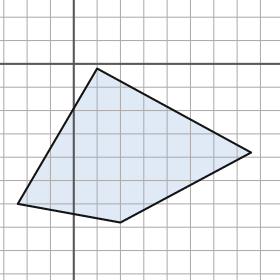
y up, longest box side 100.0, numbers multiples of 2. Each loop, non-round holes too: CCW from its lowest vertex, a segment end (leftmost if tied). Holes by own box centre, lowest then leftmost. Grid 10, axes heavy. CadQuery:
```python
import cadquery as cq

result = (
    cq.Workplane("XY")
    .moveTo(20.0, -68.0)
    .lineTo(76.0, -38.0)
    .lineTo(10.0, -2.0)
    .lineTo(-24.0, -60.0)
    .close()
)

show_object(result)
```